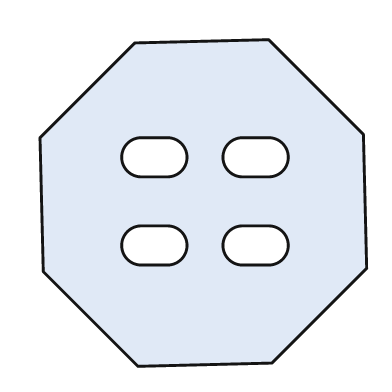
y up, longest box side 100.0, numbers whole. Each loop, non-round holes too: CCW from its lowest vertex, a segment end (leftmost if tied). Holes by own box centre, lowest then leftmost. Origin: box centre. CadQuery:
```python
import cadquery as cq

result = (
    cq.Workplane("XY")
    .moveTo(-20.0, -50.0)
    .lineTo(21.0, -49.0)
    .lineTo(50.0, -20.0)
    .lineTo(49.0, 21.0)
    .lineTo(20.0, 50.0)
    .lineTo(-21.0, 49.0)
    .lineTo(-50.0, 20.0)
    .lineTo(-49.0, -21.0)
    .close()
    .moveTo(-19.0, -19.0)
    .lineTo(-11.0, -19.0)
    .threePointArc((-5.0, -13.0), (-11.0, -7.0))
    .lineTo(-19.0, -7.0)
    .threePointArc((-25.0, -13.0), (-19.0, -19.0))
    .close()
    .moveTo(12.0, -19.0)
    .lineTo(20.0, -19.0)
    .threePointArc((26.0, -13.0), (20.0, -7.0))
    .lineTo(12.0, -7.0)
    .threePointArc((6.0, -13.0), (12.0, -19.0))
    .close()
    .moveTo(-19.0, 8.0)
    .lineTo(-11.0, 8.0)
    .threePointArc((-5.0, 14.0), (-11.0, 20.0))
    .lineTo(-19.0, 20.0)
    .threePointArc((-25.0, 14.0), (-19.0, 8.0))
    .close()
    .moveTo(12.0, 8.0)
    .lineTo(20.0, 8.0)
    .threePointArc((26.0, 14.0), (20.0, 20.0))
    .lineTo(12.0, 20.0)
    .threePointArc((6.0, 14.0), (12.0, 8.0))
    .close()
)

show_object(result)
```